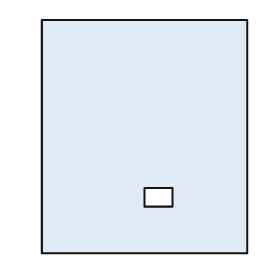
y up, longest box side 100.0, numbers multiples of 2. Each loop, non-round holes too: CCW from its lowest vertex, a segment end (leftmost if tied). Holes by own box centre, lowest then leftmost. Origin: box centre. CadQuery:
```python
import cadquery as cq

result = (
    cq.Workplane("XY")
    .moveTo(-44.0, -50.0)
    .lineTo(44.0, -50.0)
    .lineTo(44.0, 50.0)
    .lineTo(-44.0, 50.0)
    .close()
    .moveTo(0.0, -30.0)
    .lineTo(12.0, -30.0)
    .lineTo(12.0, -22.0)
    .lineTo(0.0, -22.0)
    .close()
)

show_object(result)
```